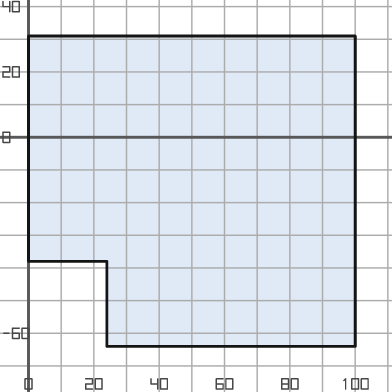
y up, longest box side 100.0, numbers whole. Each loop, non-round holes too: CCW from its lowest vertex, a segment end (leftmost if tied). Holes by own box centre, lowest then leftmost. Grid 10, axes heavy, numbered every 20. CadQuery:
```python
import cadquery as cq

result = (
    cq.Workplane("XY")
    .moveTo(24.0, -64.0)
    .lineTo(100.0, -64.0)
    .lineTo(100.0, 31.0)
    .lineTo(0.0, 31.0)
    .lineTo(0.0, -38.0)
    .lineTo(24.0, -38.0)
    .close()
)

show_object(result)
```